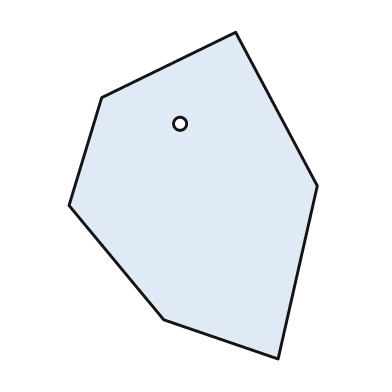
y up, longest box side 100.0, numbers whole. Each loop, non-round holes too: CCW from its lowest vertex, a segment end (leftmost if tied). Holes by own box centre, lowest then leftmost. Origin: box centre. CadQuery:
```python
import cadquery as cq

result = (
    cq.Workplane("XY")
    .moveTo(26.0, -50.0)
    .lineTo(38.0, 3.0)
    .lineTo(13.0, 50.0)
    .lineTo(-28.0, 30.0)
    .lineTo(-38.0, -3.0)
    .lineTo(-9.0, -38.0)
    .close()
    .moveTo(-4.0, 22.0)
    .circle(2.0)
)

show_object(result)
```